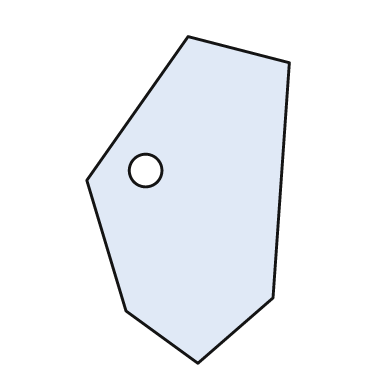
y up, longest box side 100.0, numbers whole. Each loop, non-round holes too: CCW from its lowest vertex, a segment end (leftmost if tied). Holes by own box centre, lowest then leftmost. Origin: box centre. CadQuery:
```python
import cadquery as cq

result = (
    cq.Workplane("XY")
    .moveTo(3.0, -50.0)
    .lineTo(26.0, -30.0)
    .lineTo(31.0, 42.0)
    .lineTo(0.0, 50.0)
    .lineTo(-31.0, 6.0)
    .lineTo(-19.0, -34.0)
    .close()
    .moveTo(-13.0, 9.0)
    .circle(5.0)
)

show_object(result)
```